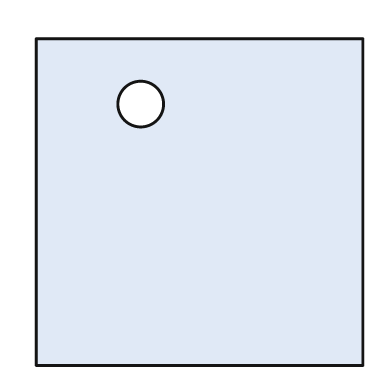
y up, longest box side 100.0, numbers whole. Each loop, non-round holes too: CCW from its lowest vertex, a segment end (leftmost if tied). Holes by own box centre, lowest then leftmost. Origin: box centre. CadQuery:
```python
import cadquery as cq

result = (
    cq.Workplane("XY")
    .moveTo(-50.0, -50.0)
    .lineTo(50.0, -50.0)
    .lineTo(50.0, 50.0)
    .lineTo(-50.0, 50.0)
    .close()
    .moveTo(-18.0, 30.0)
    .circle(7.0)
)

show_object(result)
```